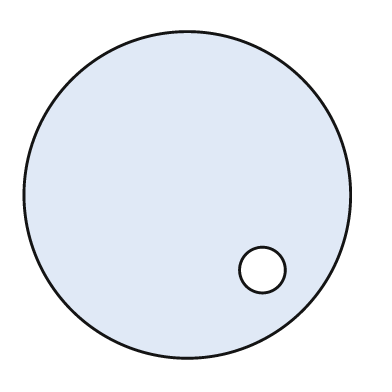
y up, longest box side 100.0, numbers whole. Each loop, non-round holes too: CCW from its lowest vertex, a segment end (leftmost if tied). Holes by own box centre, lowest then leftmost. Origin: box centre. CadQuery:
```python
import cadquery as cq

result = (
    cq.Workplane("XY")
    .moveTo(0.0, 0.0)
    .circle(50.0)
    .moveTo(23.0, -23.0)
    .circle(7.0)
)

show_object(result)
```